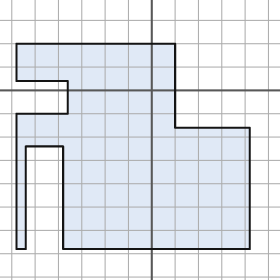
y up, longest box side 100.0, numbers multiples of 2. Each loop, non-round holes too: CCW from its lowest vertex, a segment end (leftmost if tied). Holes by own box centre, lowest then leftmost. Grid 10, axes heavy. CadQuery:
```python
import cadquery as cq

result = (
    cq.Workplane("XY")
    .moveTo(-58.0, -68.0)
    .lineTo(-54.0, -68.0)
    .lineTo(-54.0, -24.0)
    .lineTo(-38.0, -24.0)
    .lineTo(-38.0, -68.0)
    .lineTo(42.0, -68.0)
    .lineTo(42.0, -16.0)
    .lineTo(10.0, -16.0)
    .lineTo(10.0, 20.0)
    .lineTo(-58.0, 20.0)
    .lineTo(-58.0, 4.0)
    .lineTo(-36.0, 4.0)
    .lineTo(-36.0, -10.0)
    .lineTo(-58.0, -10.0)
    .close()
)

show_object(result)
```